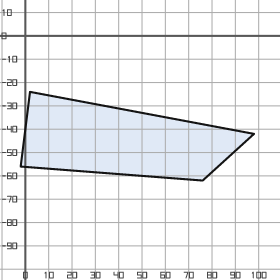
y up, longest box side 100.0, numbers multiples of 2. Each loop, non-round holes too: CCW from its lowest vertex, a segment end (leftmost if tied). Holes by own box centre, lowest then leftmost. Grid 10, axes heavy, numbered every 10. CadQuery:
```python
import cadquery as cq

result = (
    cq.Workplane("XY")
    .moveTo(76.0, -62.0)
    .lineTo(98.0, -42.0)
    .lineTo(2.0, -24.0)
    .lineTo(-2.0, -56.0)
    .close()
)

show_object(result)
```